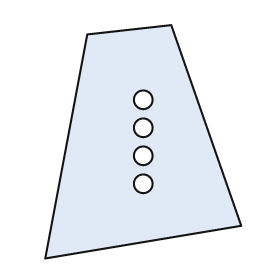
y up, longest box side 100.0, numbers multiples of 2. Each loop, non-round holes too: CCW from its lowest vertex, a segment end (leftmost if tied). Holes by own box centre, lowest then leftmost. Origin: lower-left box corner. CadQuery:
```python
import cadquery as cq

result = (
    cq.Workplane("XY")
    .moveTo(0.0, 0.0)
    .lineTo(84.0, 14.0)
    .lineTo(54.0, 100.0)
    .lineTo(18.0, 96.0)
    .close()
    .moveTo(42.0, 32.0)
    .circle(4.0)
    .moveTo(42.0, 44.0)
    .circle(4.0)
    .moveTo(42.0, 56.0)
    .circle(4.0)
    .moveTo(42.0, 68.0)
    .circle(4.0)
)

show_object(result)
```